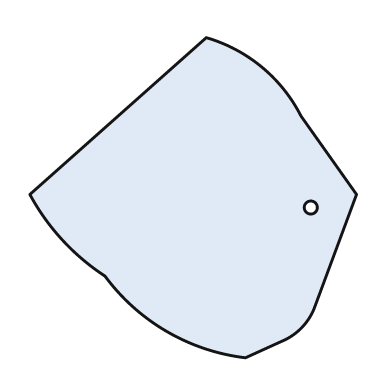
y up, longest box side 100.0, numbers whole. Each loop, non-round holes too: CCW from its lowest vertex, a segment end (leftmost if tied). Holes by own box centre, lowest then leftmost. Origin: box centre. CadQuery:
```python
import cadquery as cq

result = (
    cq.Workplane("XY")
    .moveTo(16.0, -49.0)
    .lineTo(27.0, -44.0)
    .threePointArc((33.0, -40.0), (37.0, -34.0))
    .lineTo(50.0, 1.0)
    .lineTo(33.0, 25.0)
    .threePointArc((21.0, 40.0), (4.0, 49.0))
    .lineTo(-50.0, 1.0)
    .threePointArc((-40.0, -13.0), (-27.0, -24.0))
    .threePointArc((-8.0, -41.0), (16.0, -49.0))
    .close()
    .moveTo(36.0, -3.0)
    .circle(2.0)
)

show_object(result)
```